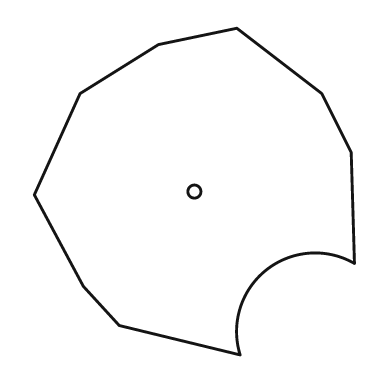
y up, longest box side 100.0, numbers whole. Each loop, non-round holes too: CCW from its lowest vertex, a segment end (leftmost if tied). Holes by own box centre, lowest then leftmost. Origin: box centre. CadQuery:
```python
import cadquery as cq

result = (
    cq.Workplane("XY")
    .moveTo(14.0, -50.0)
    .threePointArc((22.0, -24.0), (49.0, -22.0))
    .lineTo(48.0, 12.0)
    .lineTo(39.0, 30.0)
    .lineTo(13.0, 50.0)
    .lineTo(-11.0, 45.0)
    .lineTo(-35.0, 30.0)
    .lineTo(-49.0, -1.0)
    .lineTo(-34.0, -29.0)
    .lineTo(-23.0, -41.0)
    .close()
    .moveTo(0.0, 0.0)
    .circle(2.0)
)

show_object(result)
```